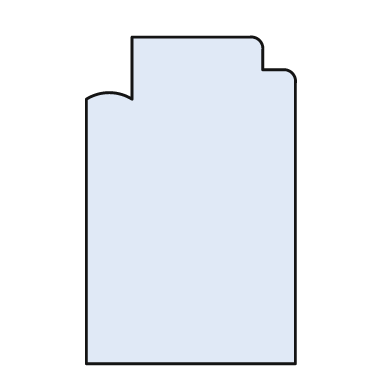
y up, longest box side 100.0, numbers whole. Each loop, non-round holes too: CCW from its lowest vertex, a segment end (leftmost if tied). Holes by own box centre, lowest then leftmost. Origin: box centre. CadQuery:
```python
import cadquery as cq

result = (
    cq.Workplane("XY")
    .moveTo(-32.0, -50.0)
    .lineTo(32.0, -50.0)
    .lineTo(32.0, 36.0)
    .threePointArc((31.0, 39.0), (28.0, 40.0))
    .lineTo(22.0, 40.0)
    .lineTo(22.0, 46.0)
    .threePointArc((21.0, 49.0), (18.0, 50.0))
    .lineTo(-18.0, 50.0)
    .lineTo(-18.0, 31.0)
    .threePointArc((-25.0, 33.0), (-32.0, 31.0))
    .close()
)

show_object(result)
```